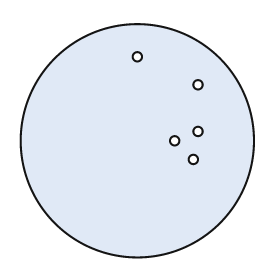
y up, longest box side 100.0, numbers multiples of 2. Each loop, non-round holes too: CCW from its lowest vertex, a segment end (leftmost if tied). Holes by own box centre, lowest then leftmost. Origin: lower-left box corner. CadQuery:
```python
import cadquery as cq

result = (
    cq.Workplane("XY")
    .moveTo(50.0, 50.0)
    .circle(50.0)
    .moveTo(74.0, 42.0)
    .circle(2.0)
    .moveTo(66.0, 50.0)
    .circle(2.0)
    .moveTo(76.0, 54.0)
    .circle(2.0)
    .moveTo(76.0, 74.0)
    .circle(2.0)
    .moveTo(50.0, 86.0)
    .circle(2.0)
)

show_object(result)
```